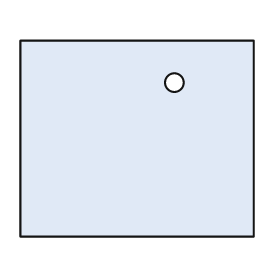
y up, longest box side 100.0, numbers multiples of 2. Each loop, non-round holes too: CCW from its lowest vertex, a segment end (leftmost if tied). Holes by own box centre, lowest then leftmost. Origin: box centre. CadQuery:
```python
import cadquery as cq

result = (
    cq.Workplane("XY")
    .moveTo(-50.0, -42.0)
    .lineTo(50.0, -42.0)
    .lineTo(50.0, 42.0)
    .lineTo(-50.0, 42.0)
    .close()
    .moveTo(16.0, 24.0)
    .circle(4.0)
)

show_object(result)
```